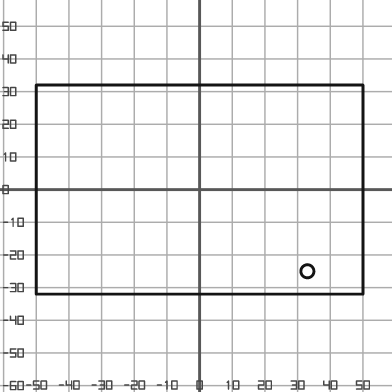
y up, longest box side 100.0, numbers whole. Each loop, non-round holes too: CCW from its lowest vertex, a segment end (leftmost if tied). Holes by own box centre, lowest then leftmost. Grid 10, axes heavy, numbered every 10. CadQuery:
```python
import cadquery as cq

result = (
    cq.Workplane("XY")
    .moveTo(-50.0, -32.0)
    .lineTo(50.0, -32.0)
    .lineTo(50.0, 32.0)
    .lineTo(-50.0, 32.0)
    .close()
    .moveTo(33.0, -25.0)
    .circle(2.0)
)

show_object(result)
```